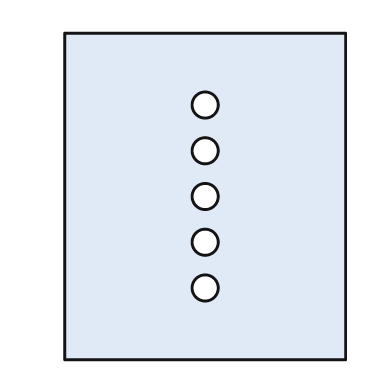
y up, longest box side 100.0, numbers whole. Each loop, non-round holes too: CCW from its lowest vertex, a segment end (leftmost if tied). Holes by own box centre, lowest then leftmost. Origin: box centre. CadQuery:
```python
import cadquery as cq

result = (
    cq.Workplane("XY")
    .moveTo(-43.0, -50.0)
    .lineTo(43.0, -50.0)
    .lineTo(43.0, 50.0)
    .lineTo(-43.0, 50.0)
    .close()
    .moveTo(0.0, -28.0)
    .circle(4.0)
    .moveTo(0.0, -14.0)
    .circle(4.0)
    .moveTo(0.0, 0.0)
    .circle(4.0)
    .moveTo(0.0, 14.0)
    .circle(4.0)
    .moveTo(0.0, 28.0)
    .circle(4.0)
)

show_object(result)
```